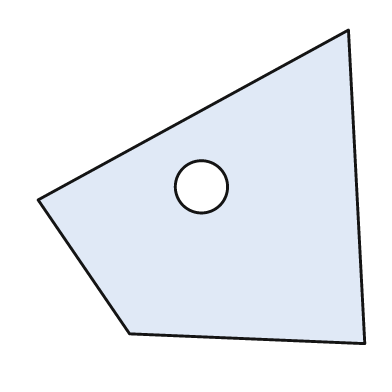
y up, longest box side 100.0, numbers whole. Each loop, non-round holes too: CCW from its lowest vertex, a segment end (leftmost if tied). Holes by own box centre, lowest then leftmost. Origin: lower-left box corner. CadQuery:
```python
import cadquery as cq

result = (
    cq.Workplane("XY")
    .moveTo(100.0, 0.0)
    .lineTo(95.0, 96.0)
    .lineTo(0.0, 44.0)
    .lineTo(28.0, 3.0)
    .close()
    .moveTo(50.0, 48.0)
    .circle(8.0)
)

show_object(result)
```